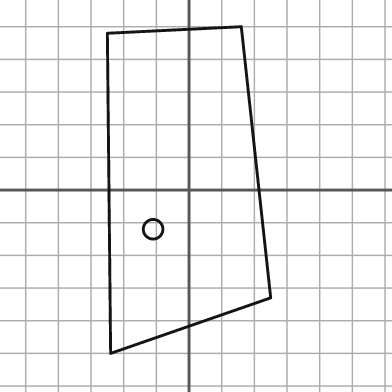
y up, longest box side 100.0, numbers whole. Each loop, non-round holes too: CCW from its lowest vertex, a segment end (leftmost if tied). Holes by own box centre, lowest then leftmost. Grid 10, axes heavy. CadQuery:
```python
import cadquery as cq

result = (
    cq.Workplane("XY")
    .moveTo(-24.0, -50.0)
    .lineTo(25.0, -33.0)
    .lineTo(16.0, 50.0)
    .lineTo(-25.0, 48.0)
    .close()
    .moveTo(-11.0, -12.0)
    .circle(3.0)
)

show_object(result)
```